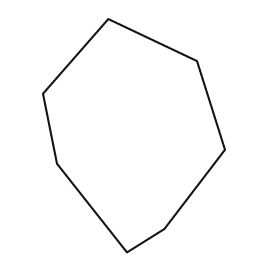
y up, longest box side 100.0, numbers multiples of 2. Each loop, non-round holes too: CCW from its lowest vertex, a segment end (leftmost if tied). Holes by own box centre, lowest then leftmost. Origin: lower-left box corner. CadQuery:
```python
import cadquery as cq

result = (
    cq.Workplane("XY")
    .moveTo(36.0, 0.0)
    .lineTo(52.0, 10.0)
    .lineTo(78.0, 44.0)
    .lineTo(66.0, 82.0)
    .lineTo(28.0, 100.0)
    .lineTo(0.0, 68.0)
    .lineTo(6.0, 38.0)
    .close()
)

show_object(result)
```